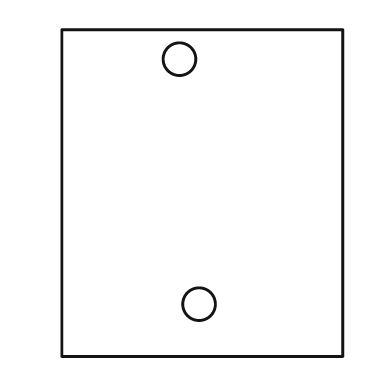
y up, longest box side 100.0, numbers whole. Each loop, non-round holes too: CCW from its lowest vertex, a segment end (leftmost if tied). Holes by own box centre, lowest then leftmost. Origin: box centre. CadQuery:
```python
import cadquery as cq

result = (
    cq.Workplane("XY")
    .moveTo(-43.0, -50.0)
    .lineTo(43.0, -50.0)
    .lineTo(43.0, 50.0)
    .lineTo(-43.0, 50.0)
    .close()
    .moveTo(-1.0, -34.0)
    .circle(5.0)
    .moveTo(-7.0, 41.0)
    .circle(5.0)
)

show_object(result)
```